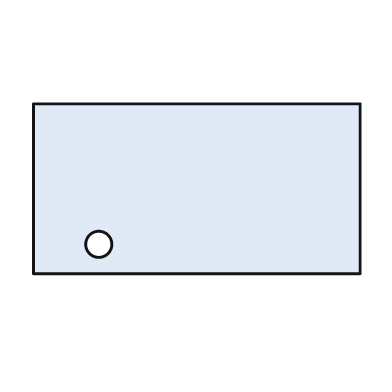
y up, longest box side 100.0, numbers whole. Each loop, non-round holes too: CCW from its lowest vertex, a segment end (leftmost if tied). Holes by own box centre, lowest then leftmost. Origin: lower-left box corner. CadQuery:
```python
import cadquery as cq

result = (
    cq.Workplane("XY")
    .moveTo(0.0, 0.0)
    .lineTo(100.0, 0.0)
    .lineTo(100.0, 52.0)
    .lineTo(0.0, 52.0)
    .close()
    .moveTo(20.0, 9.0)
    .circle(4.0)
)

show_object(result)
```